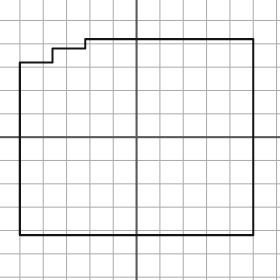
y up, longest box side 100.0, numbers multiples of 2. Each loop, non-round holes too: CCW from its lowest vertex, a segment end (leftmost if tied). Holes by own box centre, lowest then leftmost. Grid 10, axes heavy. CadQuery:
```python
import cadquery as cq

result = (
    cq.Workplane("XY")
    .moveTo(-50.0, -42.0)
    .lineTo(50.0, -42.0)
    .lineTo(50.0, 42.0)
    .lineTo(-22.0, 42.0)
    .lineTo(-22.0, 38.0)
    .lineTo(-36.0, 38.0)
    .lineTo(-36.0, 32.0)
    .lineTo(-50.0, 32.0)
    .close()
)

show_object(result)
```